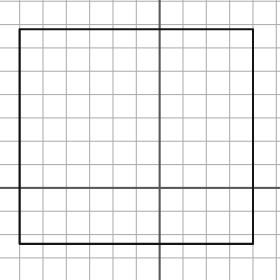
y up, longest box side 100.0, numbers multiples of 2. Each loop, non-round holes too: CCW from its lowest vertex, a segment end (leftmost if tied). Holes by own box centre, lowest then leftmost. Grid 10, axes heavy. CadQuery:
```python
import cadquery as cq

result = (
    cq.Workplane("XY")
    .moveTo(-60.0, -24.0)
    .lineTo(40.0, -24.0)
    .lineTo(40.0, 68.0)
    .lineTo(-60.0, 68.0)
    .close()
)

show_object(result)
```